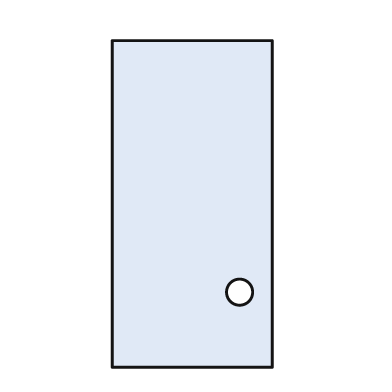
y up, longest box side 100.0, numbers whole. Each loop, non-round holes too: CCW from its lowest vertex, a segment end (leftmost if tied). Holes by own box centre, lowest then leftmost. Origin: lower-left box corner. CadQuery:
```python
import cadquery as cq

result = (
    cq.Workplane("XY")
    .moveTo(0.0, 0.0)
    .lineTo(49.0, 0.0)
    .lineTo(49.0, 100.0)
    .lineTo(0.0, 100.0)
    .close()
    .moveTo(39.0, 23.0)
    .circle(4.0)
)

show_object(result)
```